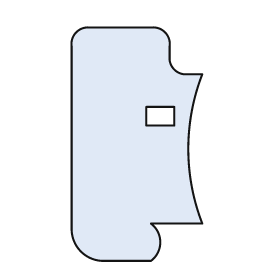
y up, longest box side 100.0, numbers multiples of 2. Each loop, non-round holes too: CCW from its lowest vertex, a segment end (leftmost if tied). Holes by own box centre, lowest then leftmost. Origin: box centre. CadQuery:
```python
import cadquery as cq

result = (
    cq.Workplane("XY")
    .moveTo(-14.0, -50.0)
    .lineTo(6.0, -50.0)
    .threePointArc((10.0, -42.0), (6.0, -34.0))
    .lineTo(28.0, -34.0)
    .threePointArc((22.0, -2.0), (28.0, 30.0))
    .lineTo(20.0, 30.0)
    .threePointArc((16.0, 32.0), (14.0, 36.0))
    .lineTo(14.0, 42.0)
    .threePointArc((12.0, 48.0), (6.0, 50.0))
    .lineTo(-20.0, 50.0)
    .threePointArc((-26.0, 48.0), (-28.0, 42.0))
    .lineTo(-28.0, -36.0)
    .threePointArc((-24.0, -46.0), (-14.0, -50.0))
    .close()
    .moveTo(4.0, 8.0)
    .lineTo(16.0, 8.0)
    .lineTo(16.0, 16.0)
    .lineTo(4.0, 16.0)
    .close()
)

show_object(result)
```